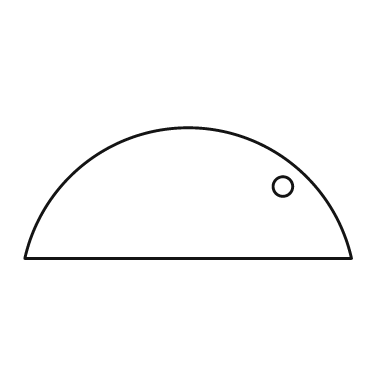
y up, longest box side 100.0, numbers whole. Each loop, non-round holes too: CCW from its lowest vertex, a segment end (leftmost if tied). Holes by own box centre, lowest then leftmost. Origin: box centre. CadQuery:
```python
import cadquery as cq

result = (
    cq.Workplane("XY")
    .moveTo(-50.0, -20.0)
    .lineTo(50.0, -20.0)
    .threePointArc((0.0, 20.0), (-50.0, -20.0))
    .close()
    .moveTo(29.0, 2.0)
    .circle(3.0)
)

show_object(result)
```